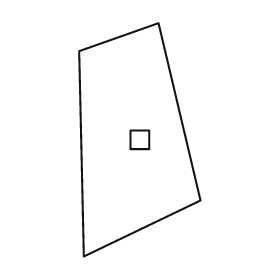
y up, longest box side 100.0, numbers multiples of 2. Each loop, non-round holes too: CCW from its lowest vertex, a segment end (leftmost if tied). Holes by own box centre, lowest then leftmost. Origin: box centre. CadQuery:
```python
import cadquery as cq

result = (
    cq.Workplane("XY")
    .moveTo(-24.0, -50.0)
    .lineTo(26.0, -26.0)
    .lineTo(8.0, 50.0)
    .lineTo(-26.0, 38.0)
    .close()
    .moveTo(-4.0, -4.0)
    .lineTo(4.0, -4.0)
    .lineTo(4.0, 4.0)
    .lineTo(-4.0, 4.0)
    .close()
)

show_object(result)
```